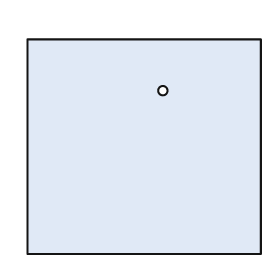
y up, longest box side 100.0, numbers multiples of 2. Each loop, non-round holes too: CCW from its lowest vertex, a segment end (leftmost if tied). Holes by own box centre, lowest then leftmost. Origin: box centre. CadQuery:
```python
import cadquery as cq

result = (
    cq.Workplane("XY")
    .moveTo(-50.0, -46.0)
    .lineTo(50.0, -46.0)
    .lineTo(50.0, 46.0)
    .lineTo(-50.0, 46.0)
    .close()
    .moveTo(8.0, 24.0)
    .circle(2.0)
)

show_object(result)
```